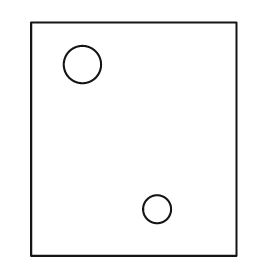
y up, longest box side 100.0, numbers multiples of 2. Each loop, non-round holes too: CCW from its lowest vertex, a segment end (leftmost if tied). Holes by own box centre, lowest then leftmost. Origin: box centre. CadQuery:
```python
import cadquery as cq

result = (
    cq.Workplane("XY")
    .moveTo(-44.0, -50.0)
    .lineTo(44.0, -50.0)
    .lineTo(44.0, 50.0)
    .lineTo(-44.0, 50.0)
    .close()
    .moveTo(10.0, -30.0)
    .circle(6.0)
    .moveTo(-22.0, 32.0)
    .circle(8.0)
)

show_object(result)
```